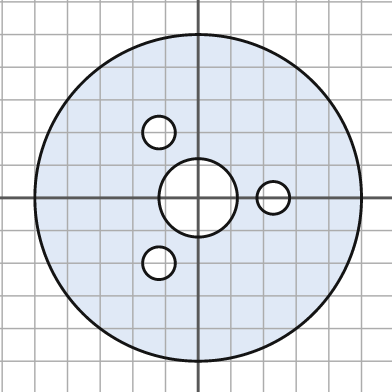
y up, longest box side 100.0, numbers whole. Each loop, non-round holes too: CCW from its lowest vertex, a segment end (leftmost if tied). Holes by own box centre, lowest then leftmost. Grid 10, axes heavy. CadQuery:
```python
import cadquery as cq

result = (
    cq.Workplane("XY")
    .moveTo(0.0, 0.0)
    .circle(50.0)
    .moveTo(-12.0, -20.0)
    .circle(5.0)
    .moveTo(0.0, 0.0)
    .circle(12.0)
    .moveTo(23.0, 0.0)
    .circle(5.0)
    .moveTo(-12.0, 20.0)
    .circle(5.0)
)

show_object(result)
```